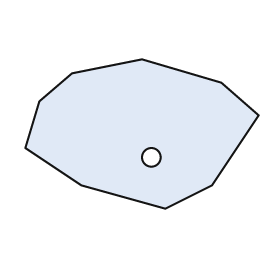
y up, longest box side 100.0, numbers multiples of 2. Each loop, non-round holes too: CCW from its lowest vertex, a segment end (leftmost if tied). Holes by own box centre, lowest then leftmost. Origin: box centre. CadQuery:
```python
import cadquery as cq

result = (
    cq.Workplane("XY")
    .moveTo(10.0, -32.0)
    .lineTo(30.0, -22.0)
    .lineTo(50.0, 8.0)
    .lineTo(34.0, 22.0)
    .lineTo(0.0, 32.0)
    .lineTo(-30.0, 26.0)
    .lineTo(-44.0, 14.0)
    .lineTo(-50.0, -6.0)
    .lineTo(-26.0, -22.0)
    .close()
    .moveTo(4.0, -10.0)
    .circle(4.0)
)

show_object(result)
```